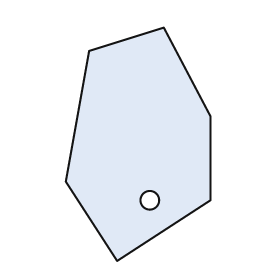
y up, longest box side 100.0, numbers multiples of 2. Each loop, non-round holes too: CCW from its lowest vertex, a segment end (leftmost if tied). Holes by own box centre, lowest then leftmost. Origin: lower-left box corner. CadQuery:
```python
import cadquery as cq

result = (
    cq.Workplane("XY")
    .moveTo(22.0, 0.0)
    .lineTo(62.0, 26.0)
    .lineTo(62.0, 62.0)
    .lineTo(42.0, 100.0)
    .lineTo(10.0, 90.0)
    .lineTo(0.0, 34.0)
    .close()
    .moveTo(36.0, 26.0)
    .circle(4.0)
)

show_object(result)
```